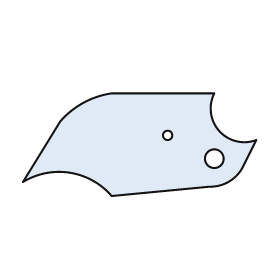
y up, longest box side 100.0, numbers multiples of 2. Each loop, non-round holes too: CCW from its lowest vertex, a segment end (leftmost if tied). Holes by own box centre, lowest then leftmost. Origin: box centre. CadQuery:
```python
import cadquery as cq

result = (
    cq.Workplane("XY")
    .moveTo(-12.0, -22.0)
    .lineTo(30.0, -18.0)
    .threePointArc((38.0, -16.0), (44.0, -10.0))
    .lineTo(50.0, 2.0)
    .threePointArc((34.0, 6.0), (32.0, 22.0))
    .lineTo(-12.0, 22.0)
    .threePointArc((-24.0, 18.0), (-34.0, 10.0))
    .lineTo(-50.0, -16.0)
    .threePointArc((-30.0, -12.0), (-12.0, -22.0))
    .close()
    .moveTo(32.0, -6.0)
    .circle(4.0)
    .moveTo(12.0, 4.0)
    .circle(2.0)
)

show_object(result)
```